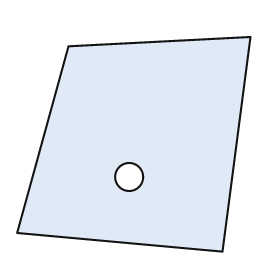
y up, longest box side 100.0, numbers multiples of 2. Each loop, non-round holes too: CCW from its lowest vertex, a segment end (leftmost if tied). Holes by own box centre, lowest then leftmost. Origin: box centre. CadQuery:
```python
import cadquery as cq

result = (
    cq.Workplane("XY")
    .moveTo(38.0, -46.0)
    .lineTo(50.0, 46.0)
    .lineTo(-28.0, 42.0)
    .lineTo(-50.0, -38.0)
    .close()
    .moveTo(-2.0, -14.0)
    .circle(6.0)
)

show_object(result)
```